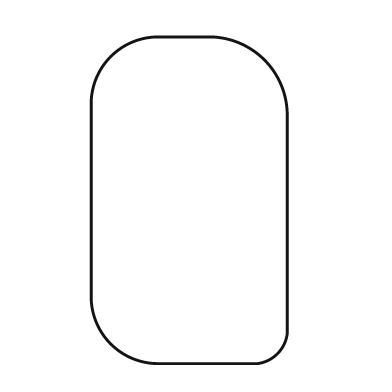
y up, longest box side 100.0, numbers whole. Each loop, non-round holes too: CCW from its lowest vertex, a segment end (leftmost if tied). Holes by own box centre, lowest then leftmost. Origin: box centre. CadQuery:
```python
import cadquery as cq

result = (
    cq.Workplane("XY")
    .moveTo(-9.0, -50.0)
    .lineTo(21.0, -50.0)
    .threePointArc((27.0, -47.0), (30.0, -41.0))
    .lineTo(30.0, 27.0)
    .threePointArc((23.0, 43.0), (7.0, 50.0))
    .lineTo(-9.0, 50.0)
    .threePointArc((-24.0, 44.0), (-30.0, 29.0))
    .lineTo(-30.0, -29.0)
    .threePointArc((-24.0, -44.0), (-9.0, -50.0))
    .close()
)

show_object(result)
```